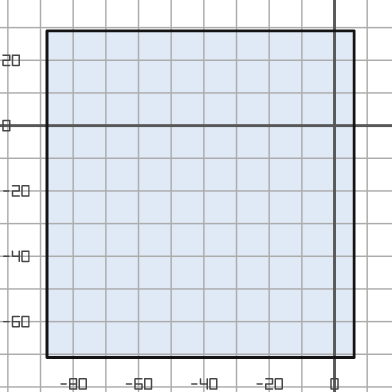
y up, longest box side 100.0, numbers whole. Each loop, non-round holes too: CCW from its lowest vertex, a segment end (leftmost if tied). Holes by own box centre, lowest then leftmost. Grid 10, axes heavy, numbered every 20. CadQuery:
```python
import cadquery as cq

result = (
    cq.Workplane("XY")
    .moveTo(-88.0, -71.0)
    .lineTo(6.0, -71.0)
    .lineTo(6.0, 29.0)
    .lineTo(-88.0, 29.0)
    .close()
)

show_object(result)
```